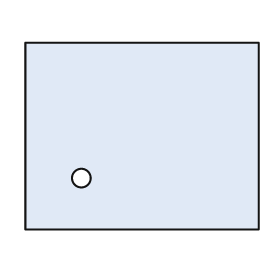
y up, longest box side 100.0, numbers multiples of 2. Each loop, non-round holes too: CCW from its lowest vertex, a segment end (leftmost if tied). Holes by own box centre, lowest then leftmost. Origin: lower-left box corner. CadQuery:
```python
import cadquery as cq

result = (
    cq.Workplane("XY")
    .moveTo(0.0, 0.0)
    .lineTo(100.0, 0.0)
    .lineTo(100.0, 80.0)
    .lineTo(0.0, 80.0)
    .close()
    .moveTo(24.0, 22.0)
    .circle(4.0)
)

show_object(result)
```